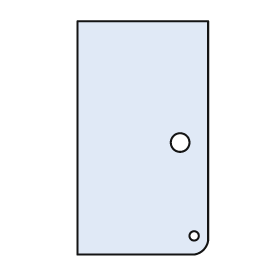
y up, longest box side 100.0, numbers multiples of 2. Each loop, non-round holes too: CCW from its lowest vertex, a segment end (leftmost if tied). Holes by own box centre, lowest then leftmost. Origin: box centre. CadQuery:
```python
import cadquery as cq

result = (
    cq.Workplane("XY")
    .moveTo(-28.0, -50.0)
    .lineTo(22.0, -50.0)
    .threePointArc((26.0, -48.0), (28.0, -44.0))
    .lineTo(28.0, 50.0)
    .lineTo(-28.0, 50.0)
    .close()
    .moveTo(22.0, -42.0)
    .circle(2.0)
    .moveTo(16.0, -2.0)
    .circle(4.0)
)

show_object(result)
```